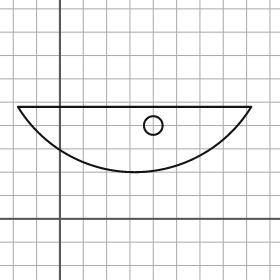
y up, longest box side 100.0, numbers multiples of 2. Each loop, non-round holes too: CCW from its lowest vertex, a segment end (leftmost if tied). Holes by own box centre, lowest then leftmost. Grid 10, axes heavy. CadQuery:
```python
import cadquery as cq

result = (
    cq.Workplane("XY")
    .moveTo(-18.0, 48.0)
    .threePointArc((32.0, 20.0), (82.0, 48.0))
    .close()
    .moveTo(40.0, 40.0)
    .circle(4.0)
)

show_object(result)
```